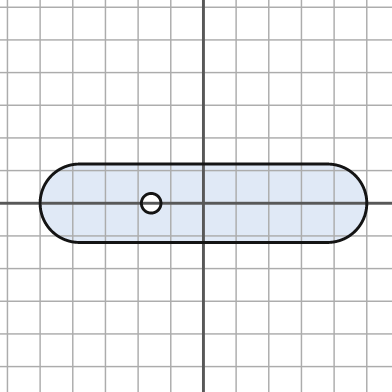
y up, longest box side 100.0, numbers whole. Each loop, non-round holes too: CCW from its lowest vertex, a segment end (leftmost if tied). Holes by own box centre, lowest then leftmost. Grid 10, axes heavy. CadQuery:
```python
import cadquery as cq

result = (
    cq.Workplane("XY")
    .moveTo(-38.0, -12.0)
    .lineTo(38.0, -12.0)
    .threePointArc((50.0, 0.0), (38.0, 12.0))
    .lineTo(-38.0, 12.0)
    .threePointArc((-50.0, 0.0), (-38.0, -12.0))
    .close()
    .moveTo(-16.0, 0.0)
    .circle(3.0)
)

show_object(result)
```